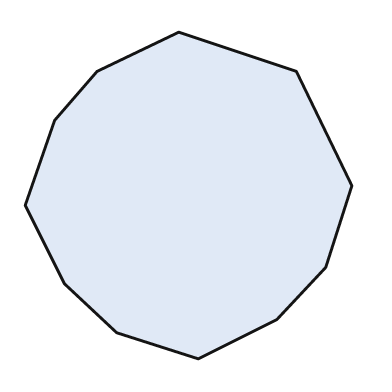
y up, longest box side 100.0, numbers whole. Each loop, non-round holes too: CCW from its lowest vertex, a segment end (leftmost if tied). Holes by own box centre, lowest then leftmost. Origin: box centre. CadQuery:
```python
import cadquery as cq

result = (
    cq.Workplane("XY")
    .moveTo(3.0, -50.0)
    .lineTo(27.0, -38.0)
    .lineTo(42.0, -22.0)
    .lineTo(50.0, 3.0)
    .lineTo(33.0, 38.0)
    .lineTo(-3.0, 50.0)
    .lineTo(-28.0, 38.0)
    .lineTo(-41.0, 23.0)
    .lineTo(-50.0, -3.0)
    .lineTo(-38.0, -27.0)
    .lineTo(-22.0, -42.0)
    .close()
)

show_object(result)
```